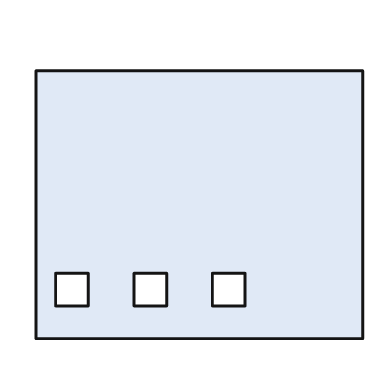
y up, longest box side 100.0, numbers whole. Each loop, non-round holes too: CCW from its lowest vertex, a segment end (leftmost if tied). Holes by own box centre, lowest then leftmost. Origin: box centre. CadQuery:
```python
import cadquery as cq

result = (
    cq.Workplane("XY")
    .moveTo(-50.0, -41.0)
    .lineTo(50.0, -41.0)
    .lineTo(50.0, 41.0)
    .lineTo(-50.0, 41.0)
    .close()
    .moveTo(-44.0, -31.0)
    .lineTo(-34.0, -31.0)
    .lineTo(-34.0, -21.0)
    .lineTo(-44.0, -21.0)
    .close()
    .moveTo(-20.0, -31.0)
    .lineTo(-10.0, -31.0)
    .lineTo(-10.0, -21.0)
    .lineTo(-20.0, -21.0)
    .close()
    .moveTo(4.0, -31.0)
    .lineTo(14.0, -31.0)
    .lineTo(14.0, -21.0)
    .lineTo(4.0, -21.0)
    .close()
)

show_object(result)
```